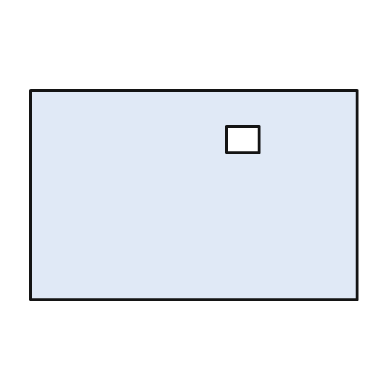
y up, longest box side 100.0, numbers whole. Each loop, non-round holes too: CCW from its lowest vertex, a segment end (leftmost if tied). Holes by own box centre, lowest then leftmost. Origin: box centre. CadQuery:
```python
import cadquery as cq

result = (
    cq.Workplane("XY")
    .moveTo(-50.0, -32.0)
    .lineTo(50.0, -32.0)
    .lineTo(50.0, 32.0)
    .lineTo(-50.0, 32.0)
    .close()
    .moveTo(10.0, 13.0)
    .lineTo(20.0, 13.0)
    .lineTo(20.0, 21.0)
    .lineTo(10.0, 21.0)
    .close()
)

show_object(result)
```